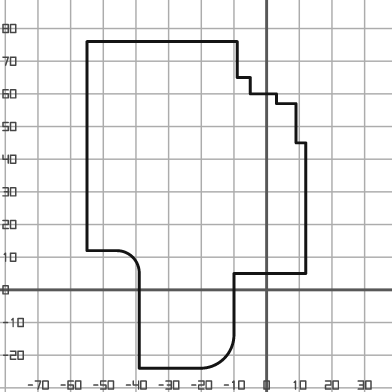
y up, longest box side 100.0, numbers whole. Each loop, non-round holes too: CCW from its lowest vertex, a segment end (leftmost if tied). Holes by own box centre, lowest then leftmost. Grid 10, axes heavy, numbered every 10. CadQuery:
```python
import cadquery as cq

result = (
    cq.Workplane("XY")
    .moveTo(-39.0, -24.0)
    .lineTo(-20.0, -24.0)
    .threePointArc((-13.0, -21.0), (-10.0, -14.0))
    .lineTo(-10.0, 5.0)
    .lineTo(12.0, 5.0)
    .lineTo(12.0, 45.0)
    .lineTo(9.0, 45.0)
    .lineTo(9.0, 57.0)
    .lineTo(3.0, 57.0)
    .lineTo(3.0, 60.0)
    .lineTo(-5.0, 60.0)
    .lineTo(-5.0, 65.0)
    .lineTo(-9.0, 65.0)
    .lineTo(-9.0, 76.0)
    .lineTo(-55.0, 76.0)
    .lineTo(-55.0, 12.0)
    .lineTo(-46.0, 12.0)
    .threePointArc((-41.0, 10.0), (-39.0, 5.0))
    .close()
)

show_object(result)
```